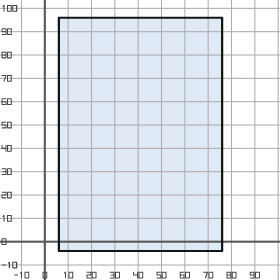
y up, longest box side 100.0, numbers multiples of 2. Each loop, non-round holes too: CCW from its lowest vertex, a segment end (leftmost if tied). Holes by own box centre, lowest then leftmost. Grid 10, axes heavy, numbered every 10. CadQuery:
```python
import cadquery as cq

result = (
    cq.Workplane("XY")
    .moveTo(6.0, -4.0)
    .lineTo(76.0, -4.0)
    .lineTo(76.0, 96.0)
    .lineTo(6.0, 96.0)
    .close()
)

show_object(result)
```